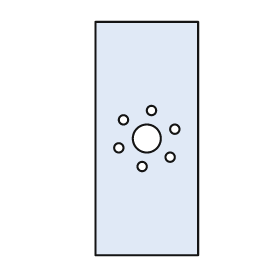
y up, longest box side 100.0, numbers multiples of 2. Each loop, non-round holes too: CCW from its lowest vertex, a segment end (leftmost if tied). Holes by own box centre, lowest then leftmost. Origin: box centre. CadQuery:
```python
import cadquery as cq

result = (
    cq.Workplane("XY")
    .moveTo(-22.0, -50.0)
    .lineTo(22.0, -50.0)
    .lineTo(22.0, 50.0)
    .lineTo(-22.0, 50.0)
    .close()
    .moveTo(-2.0, -12.0)
    .circle(2.0)
    .moveTo(10.0, -8.0)
    .circle(2.0)
    .moveTo(-12.0, -4.0)
    .circle(2.0)
    .moveTo(0.0, 0.0)
    .circle(6.0)
    .moveTo(12.0, 4.0)
    .circle(2.0)
    .moveTo(-10.0, 8.0)
    .circle(2.0)
    .moveTo(2.0, 12.0)
    .circle(2.0)
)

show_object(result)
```